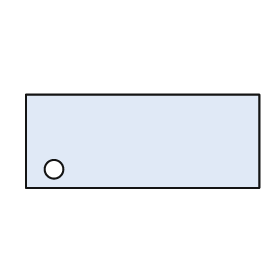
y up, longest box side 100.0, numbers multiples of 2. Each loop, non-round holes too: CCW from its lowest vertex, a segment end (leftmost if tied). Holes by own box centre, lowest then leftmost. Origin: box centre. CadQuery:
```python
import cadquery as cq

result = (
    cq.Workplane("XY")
    .moveTo(-50.0, -20.0)
    .lineTo(50.0, -20.0)
    .lineTo(50.0, 20.0)
    .lineTo(-50.0, 20.0)
    .close()
    .moveTo(-38.0, -12.0)
    .circle(4.0)
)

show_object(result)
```